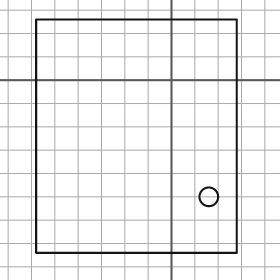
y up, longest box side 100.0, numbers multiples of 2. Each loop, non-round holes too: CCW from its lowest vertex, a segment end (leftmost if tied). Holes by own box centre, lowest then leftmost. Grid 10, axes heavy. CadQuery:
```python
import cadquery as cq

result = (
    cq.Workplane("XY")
    .moveTo(-58.0, -74.0)
    .lineTo(28.0, -74.0)
    .lineTo(28.0, 26.0)
    .lineTo(-58.0, 26.0)
    .close()
    .moveTo(16.0, -50.0)
    .circle(4.0)
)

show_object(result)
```